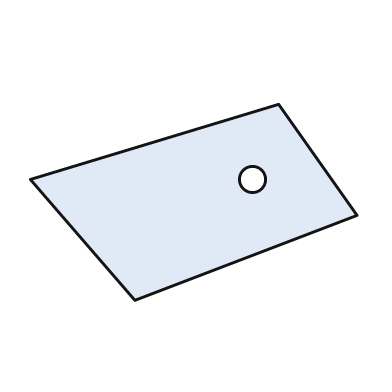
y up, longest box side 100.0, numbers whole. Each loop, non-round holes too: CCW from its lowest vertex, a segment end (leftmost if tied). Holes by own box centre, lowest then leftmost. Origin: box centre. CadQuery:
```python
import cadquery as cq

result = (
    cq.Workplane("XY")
    .moveTo(-18.0, -30.0)
    .lineTo(50.0, -4.0)
    .lineTo(26.0, 30.0)
    .lineTo(-50.0, 7.0)
    .close()
    .moveTo(18.0, 7.0)
    .circle(4.0)
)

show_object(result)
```